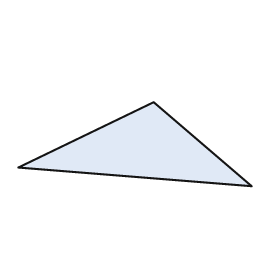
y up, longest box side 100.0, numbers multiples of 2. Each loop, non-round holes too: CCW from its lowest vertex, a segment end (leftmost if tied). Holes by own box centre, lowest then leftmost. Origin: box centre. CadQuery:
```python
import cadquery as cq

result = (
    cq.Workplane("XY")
    .moveTo(50.0, -18.0)
    .lineTo(8.0, 18.0)
    .lineTo(-50.0, -10.0)
    .close()
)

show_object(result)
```